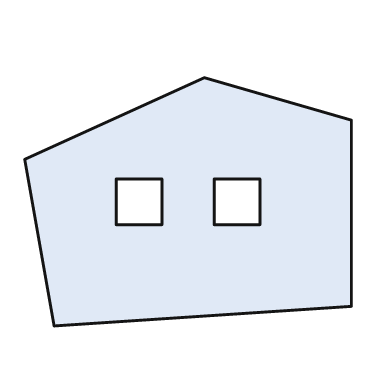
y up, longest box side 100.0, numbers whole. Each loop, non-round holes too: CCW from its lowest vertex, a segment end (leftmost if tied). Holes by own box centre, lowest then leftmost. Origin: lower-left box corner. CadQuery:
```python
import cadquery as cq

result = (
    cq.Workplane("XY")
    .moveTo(9.0, 0.0)
    .lineTo(100.0, 6.0)
    .lineTo(100.0, 63.0)
    .lineTo(55.0, 76.0)
    .lineTo(0.0, 51.0)
    .close()
    .moveTo(28.0, 31.0)
    .lineTo(42.0, 31.0)
    .lineTo(42.0, 45.0)
    .lineTo(28.0, 45.0)
    .close()
    .moveTo(58.0, 31.0)
    .lineTo(72.0, 31.0)
    .lineTo(72.0, 45.0)
    .lineTo(58.0, 45.0)
    .close()
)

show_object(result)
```